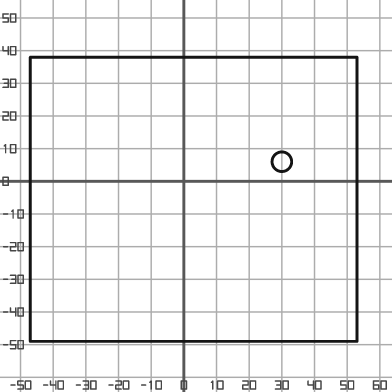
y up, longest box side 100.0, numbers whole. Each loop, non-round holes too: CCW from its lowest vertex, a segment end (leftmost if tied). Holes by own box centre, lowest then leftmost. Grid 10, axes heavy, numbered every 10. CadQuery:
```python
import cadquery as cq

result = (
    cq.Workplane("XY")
    .moveTo(-47.0, -49.0)
    .lineTo(53.0, -49.0)
    .lineTo(53.0, 38.0)
    .lineTo(-47.0, 38.0)
    .close()
    .moveTo(30.0, 6.0)
    .circle(3.0)
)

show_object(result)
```